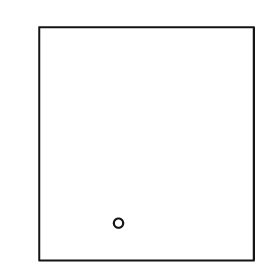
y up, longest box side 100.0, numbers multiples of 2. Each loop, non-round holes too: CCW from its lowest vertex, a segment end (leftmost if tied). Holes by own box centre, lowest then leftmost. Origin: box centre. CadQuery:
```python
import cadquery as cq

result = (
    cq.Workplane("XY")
    .moveTo(-46.0, -50.0)
    .lineTo(46.0, -50.0)
    .lineTo(46.0, 50.0)
    .lineTo(-46.0, 50.0)
    .close()
    .moveTo(-12.0, -34.0)
    .circle(2.0)
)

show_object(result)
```